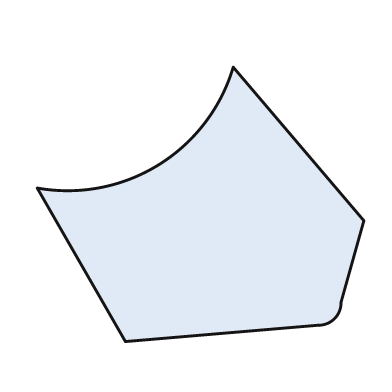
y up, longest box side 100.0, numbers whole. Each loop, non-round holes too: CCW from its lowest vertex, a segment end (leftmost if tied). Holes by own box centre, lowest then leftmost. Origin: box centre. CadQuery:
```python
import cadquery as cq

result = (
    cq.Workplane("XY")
    .moveTo(-23.0, -42.0)
    .lineTo(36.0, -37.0)
    .threePointArc((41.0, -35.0), (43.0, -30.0))
    .lineTo(50.0, -5.0)
    .lineTo(10.0, 42.0)
    .threePointArc((-13.0, 12.0), (-50.0, 5.0))
    .close()
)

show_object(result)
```